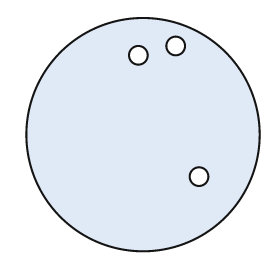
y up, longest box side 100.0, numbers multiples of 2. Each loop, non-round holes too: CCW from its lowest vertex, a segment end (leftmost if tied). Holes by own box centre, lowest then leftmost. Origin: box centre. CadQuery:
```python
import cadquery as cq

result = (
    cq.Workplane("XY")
    .moveTo(0.0, 0.0)
    .circle(50.0)
    .moveTo(24.0, -18.0)
    .circle(4.0)
    .moveTo(-2.0, 34.0)
    .circle(4.0)
    .moveTo(14.0, 38.0)
    .circle(4.0)
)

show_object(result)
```